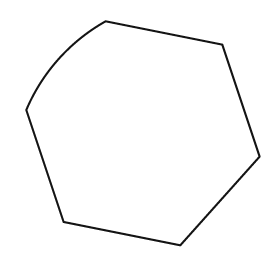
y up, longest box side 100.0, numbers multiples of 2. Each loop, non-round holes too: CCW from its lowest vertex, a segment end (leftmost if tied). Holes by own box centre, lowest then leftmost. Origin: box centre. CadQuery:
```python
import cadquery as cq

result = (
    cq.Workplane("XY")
    .moveTo(16.0, -48.0)
    .lineTo(50.0, -10.0)
    .lineTo(34.0, 38.0)
    .lineTo(-16.0, 48.0)
    .threePointArc((-36.0, 32.0), (-50.0, 10.0))
    .lineTo(-34.0, -38.0)
    .close()
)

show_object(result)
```